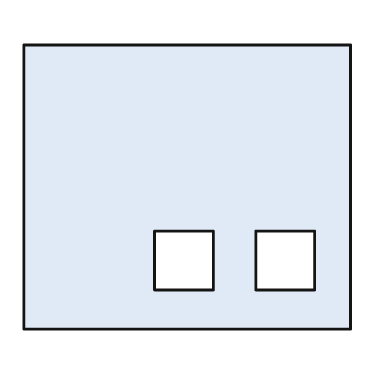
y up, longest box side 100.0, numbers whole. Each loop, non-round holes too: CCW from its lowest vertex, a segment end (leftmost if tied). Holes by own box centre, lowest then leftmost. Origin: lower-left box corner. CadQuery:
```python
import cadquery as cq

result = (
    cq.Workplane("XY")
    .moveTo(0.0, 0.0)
    .lineTo(100.0, 0.0)
    .lineTo(100.0, 87.0)
    .lineTo(0.0, 87.0)
    .close()
    .moveTo(40.0, 12.0)
    .lineTo(58.0, 12.0)
    .lineTo(58.0, 30.0)
    .lineTo(40.0, 30.0)
    .close()
    .moveTo(71.0, 12.0)
    .lineTo(89.0, 12.0)
    .lineTo(89.0, 30.0)
    .lineTo(71.0, 30.0)
    .close()
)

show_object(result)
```